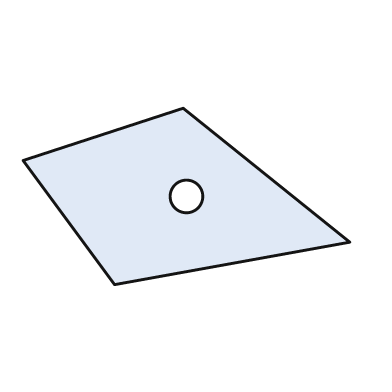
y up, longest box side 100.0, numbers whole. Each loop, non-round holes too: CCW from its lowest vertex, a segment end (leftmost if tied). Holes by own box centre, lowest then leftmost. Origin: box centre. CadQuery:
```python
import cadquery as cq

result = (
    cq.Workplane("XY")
    .moveTo(-22.0, -27.0)
    .lineTo(50.0, -14.0)
    .lineTo(-1.0, 27.0)
    .lineTo(-50.0, 11.0)
    .close()
    .moveTo(0.0, 0.0)
    .circle(5.0)
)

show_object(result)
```